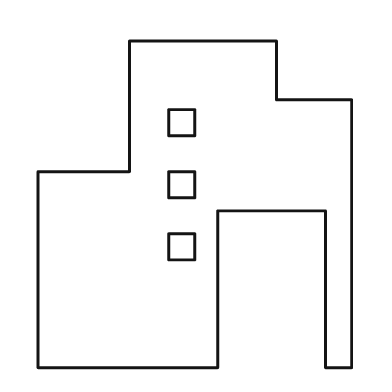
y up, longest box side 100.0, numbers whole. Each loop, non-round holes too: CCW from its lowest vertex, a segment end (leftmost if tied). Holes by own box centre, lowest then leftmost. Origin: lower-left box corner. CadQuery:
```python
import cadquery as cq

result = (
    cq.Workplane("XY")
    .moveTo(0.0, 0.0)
    .lineTo(55.0, 0.0)
    .lineTo(55.0, 48.0)
    .lineTo(88.0, 48.0)
    .lineTo(88.0, 0.0)
    .lineTo(96.0, 0.0)
    .lineTo(96.0, 82.0)
    .lineTo(73.0, 82.0)
    .lineTo(73.0, 100.0)
    .lineTo(28.0, 100.0)
    .lineTo(28.0, 60.0)
    .lineTo(0.0, 60.0)
    .close()
    .moveTo(40.0, 33.0)
    .lineTo(48.0, 33.0)
    .lineTo(48.0, 41.0)
    .lineTo(40.0, 41.0)
    .close()
    .moveTo(40.0, 52.0)
    .lineTo(48.0, 52.0)
    .lineTo(48.0, 60.0)
    .lineTo(40.0, 60.0)
    .close()
    .moveTo(40.0, 71.0)
    .lineTo(48.0, 71.0)
    .lineTo(48.0, 79.0)
    .lineTo(40.0, 79.0)
    .close()
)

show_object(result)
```